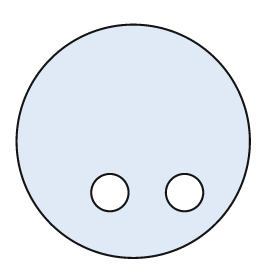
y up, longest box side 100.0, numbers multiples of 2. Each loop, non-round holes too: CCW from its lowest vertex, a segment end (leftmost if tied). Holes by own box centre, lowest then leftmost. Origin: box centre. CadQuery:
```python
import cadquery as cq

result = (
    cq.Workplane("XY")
    .moveTo(0.0, 0.0)
    .circle(50.0)
    .moveTo(-10.0, -22.0)
    .circle(8.0)
    .moveTo(22.0, -22.0)
    .circle(8.0)
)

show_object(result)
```